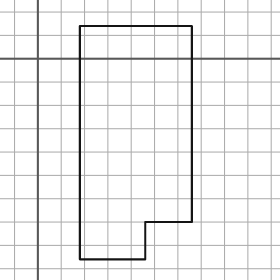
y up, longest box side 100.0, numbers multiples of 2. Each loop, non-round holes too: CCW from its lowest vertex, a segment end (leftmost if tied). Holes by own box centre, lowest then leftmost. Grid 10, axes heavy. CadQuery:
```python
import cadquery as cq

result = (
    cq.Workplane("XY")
    .moveTo(18.0, -86.0)
    .lineTo(46.0, -86.0)
    .lineTo(46.0, -70.0)
    .lineTo(66.0, -70.0)
    .lineTo(66.0, 14.0)
    .lineTo(18.0, 14.0)
    .close()
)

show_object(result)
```